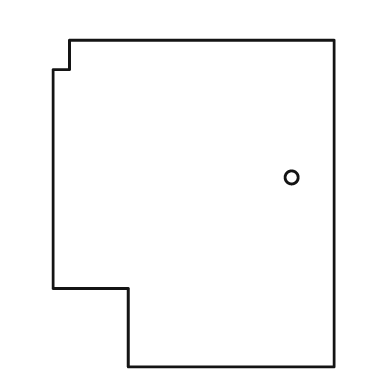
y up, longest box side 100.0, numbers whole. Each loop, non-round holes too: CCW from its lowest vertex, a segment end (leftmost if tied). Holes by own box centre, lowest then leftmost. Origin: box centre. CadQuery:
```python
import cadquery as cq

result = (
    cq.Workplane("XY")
    .moveTo(-20.0, -50.0)
    .lineTo(43.0, -50.0)
    .lineTo(43.0, 50.0)
    .lineTo(-38.0, 50.0)
    .lineTo(-38.0, 41.0)
    .lineTo(-43.0, 41.0)
    .lineTo(-43.0, -26.0)
    .lineTo(-20.0, -26.0)
    .close()
    .moveTo(30.0, 8.0)
    .circle(2.0)
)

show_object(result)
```